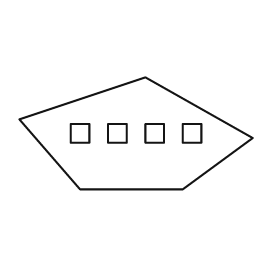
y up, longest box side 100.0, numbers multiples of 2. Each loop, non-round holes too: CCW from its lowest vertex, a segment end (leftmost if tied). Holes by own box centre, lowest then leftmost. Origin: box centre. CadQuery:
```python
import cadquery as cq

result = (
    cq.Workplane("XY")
    .moveTo(-24.0, -24.0)
    .lineTo(20.0, -24.0)
    .lineTo(50.0, -2.0)
    .lineTo(4.0, 24.0)
    .lineTo(-50.0, 6.0)
    .close()
    .moveTo(-28.0, -4.0)
    .lineTo(-20.0, -4.0)
    .lineTo(-20.0, 4.0)
    .lineTo(-28.0, 4.0)
    .close()
    .moveTo(-12.0, -4.0)
    .lineTo(-4.0, -4.0)
    .lineTo(-4.0, 4.0)
    .lineTo(-12.0, 4.0)
    .close()
    .moveTo(4.0, -4.0)
    .lineTo(12.0, -4.0)
    .lineTo(12.0, 4.0)
    .lineTo(4.0, 4.0)
    .close()
    .moveTo(20.0, -4.0)
    .lineTo(28.0, -4.0)
    .lineTo(28.0, 4.0)
    .lineTo(20.0, 4.0)
    .close()
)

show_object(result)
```